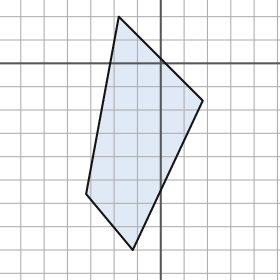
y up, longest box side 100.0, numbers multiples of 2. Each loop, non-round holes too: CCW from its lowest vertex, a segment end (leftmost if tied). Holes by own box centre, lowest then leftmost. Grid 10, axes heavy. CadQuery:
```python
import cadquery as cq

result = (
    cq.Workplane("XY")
    .moveTo(-12.0, -80.0)
    .lineTo(18.0, -16.0)
    .lineTo(-18.0, 20.0)
    .lineTo(-32.0, -56.0)
    .close()
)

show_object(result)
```